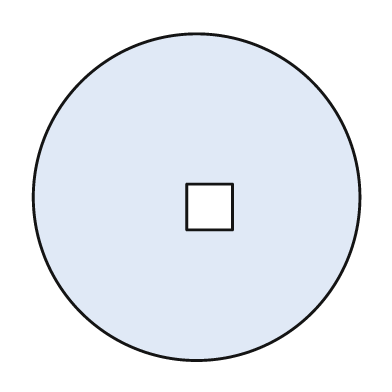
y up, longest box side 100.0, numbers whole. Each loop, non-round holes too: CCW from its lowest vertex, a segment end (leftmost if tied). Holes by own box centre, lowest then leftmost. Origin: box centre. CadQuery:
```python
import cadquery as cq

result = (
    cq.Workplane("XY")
    .moveTo(0.0, 0.0)
    .circle(50.0)
    .moveTo(-3.0, -10.0)
    .lineTo(11.0, -10.0)
    .lineTo(11.0, 4.0)
    .lineTo(-3.0, 4.0)
    .close()
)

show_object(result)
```